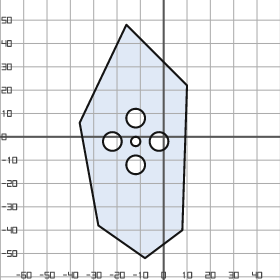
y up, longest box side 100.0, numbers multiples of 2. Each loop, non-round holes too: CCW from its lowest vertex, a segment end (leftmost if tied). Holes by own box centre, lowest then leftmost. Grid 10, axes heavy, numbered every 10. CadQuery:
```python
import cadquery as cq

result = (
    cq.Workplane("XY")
    .moveTo(-8.0, -52.0)
    .lineTo(8.0, -40.0)
    .lineTo(10.0, 22.0)
    .lineTo(-16.0, 48.0)
    .lineTo(-36.0, 6.0)
    .lineTo(-28.0, -38.0)
    .close()
    .moveTo(-12.0, -12.0)
    .circle(4.0)
    .moveTo(-22.0, -2.0)
    .circle(4.0)
    .moveTo(-12.0, -2.0)
    .circle(2.0)
    .moveTo(-2.0, -2.0)
    .circle(4.0)
    .moveTo(-12.0, 8.0)
    .circle(4.0)
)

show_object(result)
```